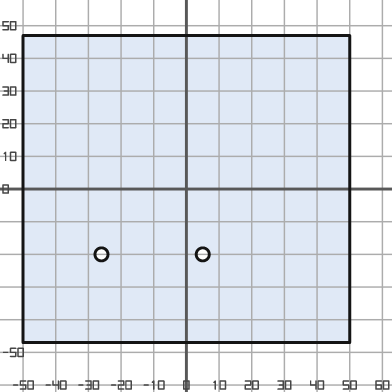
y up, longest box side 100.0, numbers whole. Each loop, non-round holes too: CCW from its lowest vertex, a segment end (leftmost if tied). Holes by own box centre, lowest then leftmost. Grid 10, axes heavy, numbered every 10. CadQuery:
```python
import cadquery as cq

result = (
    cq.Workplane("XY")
    .moveTo(-50.0, -47.0)
    .lineTo(50.0, -47.0)
    .lineTo(50.0, 47.0)
    .lineTo(-50.0, 47.0)
    .close()
    .moveTo(-26.0, -20.0)
    .circle(2.0)
    .moveTo(5.0, -20.0)
    .circle(2.0)
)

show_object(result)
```